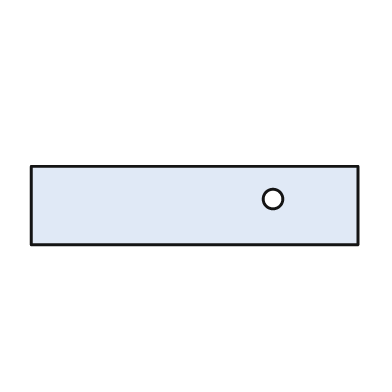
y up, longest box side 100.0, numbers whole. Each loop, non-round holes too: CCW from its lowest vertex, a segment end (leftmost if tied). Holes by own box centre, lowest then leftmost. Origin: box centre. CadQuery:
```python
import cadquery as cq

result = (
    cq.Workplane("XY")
    .moveTo(-50.0, -12.0)
    .lineTo(50.0, -12.0)
    .lineTo(50.0, 12.0)
    .lineTo(-50.0, 12.0)
    .close()
    .moveTo(24.0, 2.0)
    .circle(3.0)
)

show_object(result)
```